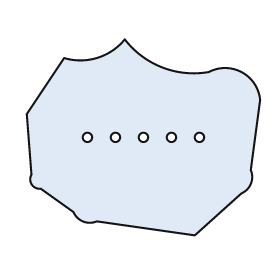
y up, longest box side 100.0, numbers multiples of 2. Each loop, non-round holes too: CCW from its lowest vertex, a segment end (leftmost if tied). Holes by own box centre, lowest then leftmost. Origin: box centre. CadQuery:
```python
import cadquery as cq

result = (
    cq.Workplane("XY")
    .moveTo(22.0, -42.0)
    .lineTo(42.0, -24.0)
    .threePointArc((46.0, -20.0), (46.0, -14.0))
    .lineTo(50.0, 16.0)
    .threePointArc((42.0, 28.0), (28.0, 28.0))
    .threePointArc((8.0, 30.0), (-8.0, 42.0))
    .threePointArc((-20.0, 34.0), (-34.0, 34.0))
    .lineTo(-50.0, 10.0)
    .lineTo(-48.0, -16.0)
    .threePointArc((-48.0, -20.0), (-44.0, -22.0))
    .lineTo(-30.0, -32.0)
    .threePointArc((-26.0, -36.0), (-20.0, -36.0))
    .close()
    .moveTo(-24.0, 0.0)
    .circle(2.0)
    .moveTo(-12.0, 0.0)
    .circle(2.0)
    .moveTo(0.0, 0.0)
    .circle(2.0)
    .moveTo(12.0, 0.0)
    .circle(2.0)
    .moveTo(24.0, 0.0)
    .circle(2.0)
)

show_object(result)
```